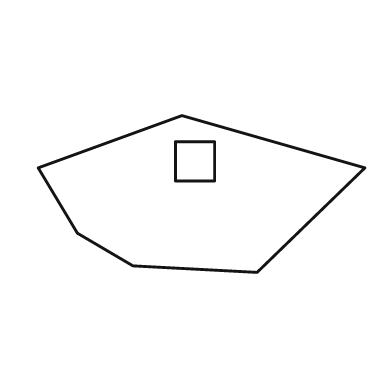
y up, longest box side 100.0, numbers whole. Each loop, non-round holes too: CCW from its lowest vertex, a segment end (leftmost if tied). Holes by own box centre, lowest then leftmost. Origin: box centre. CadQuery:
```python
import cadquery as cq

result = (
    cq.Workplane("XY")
    .moveTo(17.0, -24.0)
    .lineTo(50.0, 8.0)
    .lineTo(-6.0, 24.0)
    .lineTo(-50.0, 8.0)
    .lineTo(-38.0, -12.0)
    .lineTo(-21.0, -22.0)
    .close()
    .moveTo(-8.0, 4.0)
    .lineTo(4.0, 4.0)
    .lineTo(4.0, 16.0)
    .lineTo(-8.0, 16.0)
    .close()
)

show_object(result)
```